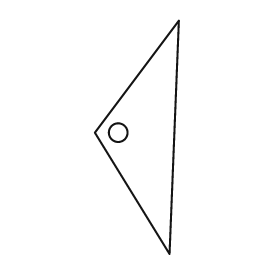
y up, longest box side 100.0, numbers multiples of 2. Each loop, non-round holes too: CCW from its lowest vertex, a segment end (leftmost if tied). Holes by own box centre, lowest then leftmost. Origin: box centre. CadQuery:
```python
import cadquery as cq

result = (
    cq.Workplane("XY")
    .moveTo(14.0, -50.0)
    .lineTo(18.0, 50.0)
    .lineTo(-18.0, 2.0)
    .close()
    .moveTo(-8.0, 2.0)
    .circle(4.0)
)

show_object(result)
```